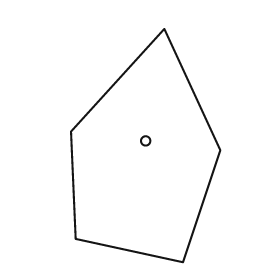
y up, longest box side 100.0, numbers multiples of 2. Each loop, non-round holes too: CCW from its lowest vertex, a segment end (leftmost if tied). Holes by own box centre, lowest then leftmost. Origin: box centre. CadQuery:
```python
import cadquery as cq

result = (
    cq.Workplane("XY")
    .moveTo(16.0, -50.0)
    .lineTo(32.0, -2.0)
    .lineTo(8.0, 50.0)
    .lineTo(-32.0, 6.0)
    .lineTo(-30.0, -40.0)
    .close()
    .moveTo(0.0, 2.0)
    .circle(2.0)
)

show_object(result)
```